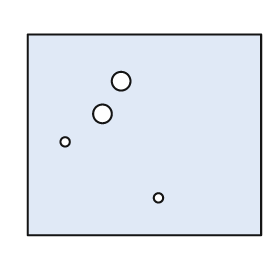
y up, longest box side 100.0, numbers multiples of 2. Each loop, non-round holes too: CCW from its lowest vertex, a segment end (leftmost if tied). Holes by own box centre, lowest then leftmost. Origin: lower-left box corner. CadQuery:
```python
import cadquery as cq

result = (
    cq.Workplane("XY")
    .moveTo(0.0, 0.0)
    .lineTo(100.0, 0.0)
    .lineTo(100.0, 86.0)
    .lineTo(0.0, 86.0)
    .close()
    .moveTo(56.0, 16.0)
    .circle(2.0)
    .moveTo(16.0, 40.0)
    .circle(2.0)
    .moveTo(32.0, 52.0)
    .circle(4.0)
    .moveTo(40.0, 66.0)
    .circle(4.0)
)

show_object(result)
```